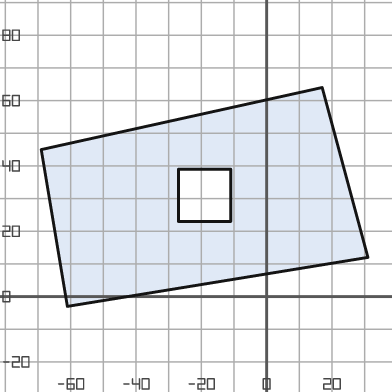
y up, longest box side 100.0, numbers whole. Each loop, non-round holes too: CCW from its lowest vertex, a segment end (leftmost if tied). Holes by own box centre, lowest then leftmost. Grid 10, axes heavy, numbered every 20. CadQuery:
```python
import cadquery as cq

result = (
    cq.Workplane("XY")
    .moveTo(-61.0, -3.0)
    .lineTo(31.0, 12.0)
    .lineTo(17.0, 64.0)
    .lineTo(-69.0, 45.0)
    .close()
    .moveTo(-27.0, 23.0)
    .lineTo(-11.0, 23.0)
    .lineTo(-11.0, 39.0)
    .lineTo(-27.0, 39.0)
    .close()
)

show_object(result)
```